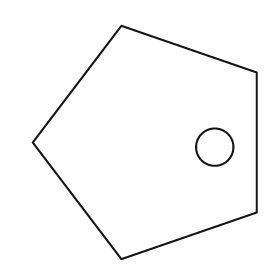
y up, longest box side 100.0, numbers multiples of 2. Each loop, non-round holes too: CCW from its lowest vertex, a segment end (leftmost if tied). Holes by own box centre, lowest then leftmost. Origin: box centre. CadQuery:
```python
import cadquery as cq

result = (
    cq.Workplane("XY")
    .moveTo(-10.0, -50.0)
    .lineTo(48.0, -30.0)
    .lineTo(48.0, 30.0)
    .lineTo(-10.0, 50.0)
    .lineTo(-48.0, 0.0)
    .close()
    .moveTo(30.0, -2.0)
    .circle(8.0)
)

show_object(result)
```